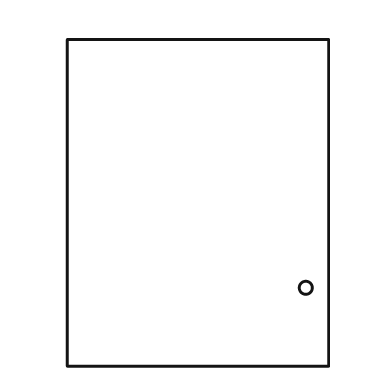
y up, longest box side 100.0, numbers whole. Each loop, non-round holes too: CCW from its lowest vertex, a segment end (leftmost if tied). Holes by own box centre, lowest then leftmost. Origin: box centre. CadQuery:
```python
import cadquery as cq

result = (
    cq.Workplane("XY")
    .moveTo(-40.0, -50.0)
    .lineTo(40.0, -50.0)
    .lineTo(40.0, 50.0)
    .lineTo(-40.0, 50.0)
    .close()
    .moveTo(33.0, -26.0)
    .circle(2.0)
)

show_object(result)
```